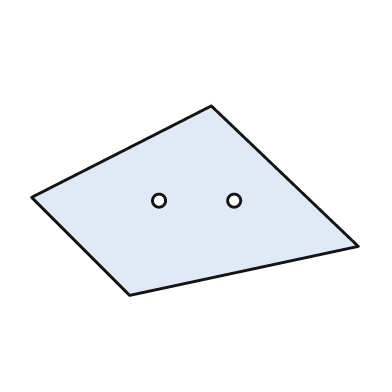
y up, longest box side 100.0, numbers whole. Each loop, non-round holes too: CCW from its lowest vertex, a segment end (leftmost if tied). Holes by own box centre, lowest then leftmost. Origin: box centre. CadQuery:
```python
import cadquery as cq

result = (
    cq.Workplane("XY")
    .moveTo(-20.0, -29.0)
    .lineTo(50.0, -14.0)
    .lineTo(5.0, 29.0)
    .lineTo(-50.0, 1.0)
    .close()
    .moveTo(-11.0, 0.0)
    .circle(2.0)
    .moveTo(12.0, 0.0)
    .circle(2.0)
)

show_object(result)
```